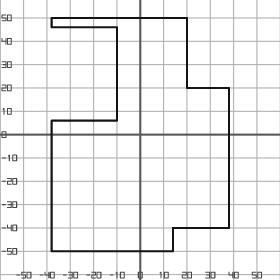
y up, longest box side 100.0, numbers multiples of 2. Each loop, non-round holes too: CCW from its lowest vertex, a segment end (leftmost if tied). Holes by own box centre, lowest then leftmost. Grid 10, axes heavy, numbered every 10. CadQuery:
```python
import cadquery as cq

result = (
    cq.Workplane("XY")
    .moveTo(-38.0, -50.0)
    .lineTo(14.0, -50.0)
    .lineTo(14.0, -40.0)
    .lineTo(38.0, -40.0)
    .lineTo(38.0, 20.0)
    .lineTo(20.0, 20.0)
    .lineTo(20.0, 50.0)
    .lineTo(-38.0, 50.0)
    .lineTo(-38.0, 46.0)
    .lineTo(-10.0, 46.0)
    .lineTo(-10.0, 6.0)
    .lineTo(-38.0, 6.0)
    .close()
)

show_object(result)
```